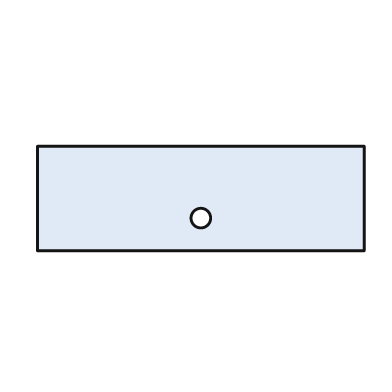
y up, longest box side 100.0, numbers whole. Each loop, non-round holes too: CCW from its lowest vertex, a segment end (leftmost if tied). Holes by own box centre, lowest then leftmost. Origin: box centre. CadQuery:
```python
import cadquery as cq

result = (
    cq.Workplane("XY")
    .moveTo(-50.0, -16.0)
    .lineTo(50.0, -16.0)
    .lineTo(50.0, 16.0)
    .lineTo(-50.0, 16.0)
    .close()
    .moveTo(0.0, -6.0)
    .circle(3.0)
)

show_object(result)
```